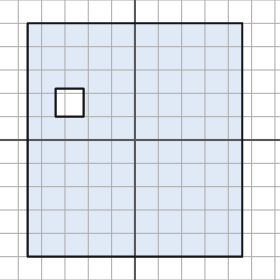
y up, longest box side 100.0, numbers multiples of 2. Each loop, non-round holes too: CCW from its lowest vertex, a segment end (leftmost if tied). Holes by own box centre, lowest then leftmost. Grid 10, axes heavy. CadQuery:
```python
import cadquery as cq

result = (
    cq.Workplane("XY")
    .moveTo(-46.0, -50.0)
    .lineTo(46.0, -50.0)
    .lineTo(46.0, 50.0)
    .lineTo(-46.0, 50.0)
    .close()
    .moveTo(-34.0, 10.0)
    .lineTo(-22.0, 10.0)
    .lineTo(-22.0, 22.0)
    .lineTo(-34.0, 22.0)
    .close()
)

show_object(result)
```